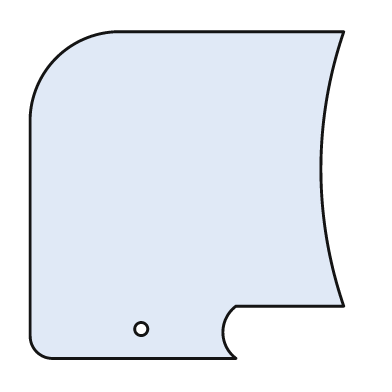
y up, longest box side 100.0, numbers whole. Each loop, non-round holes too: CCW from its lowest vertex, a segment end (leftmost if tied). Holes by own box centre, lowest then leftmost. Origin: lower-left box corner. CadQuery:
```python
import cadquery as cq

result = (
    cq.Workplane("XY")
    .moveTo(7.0, 0.0)
    .lineTo(63.0, 0.0)
    .threePointArc((59.0, 8.0), (63.0, 16.0))
    .lineTo(96.0, 16.0)
    .threePointArc((89.0, 58.0), (96.0, 100.0))
    .lineTo(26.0, 100.0)
    .threePointArc((8.0, 92.0), (0.0, 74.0))
    .lineTo(0.0, 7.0)
    .threePointArc((2.0, 2.0), (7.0, 0.0))
    .close()
    .moveTo(34.0, 9.0)
    .circle(2.0)
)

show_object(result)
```